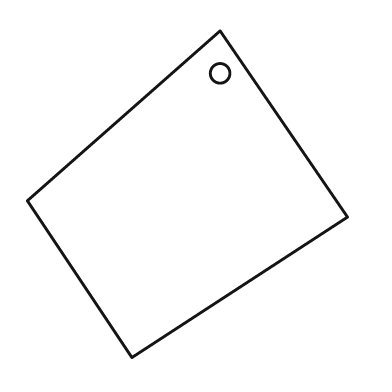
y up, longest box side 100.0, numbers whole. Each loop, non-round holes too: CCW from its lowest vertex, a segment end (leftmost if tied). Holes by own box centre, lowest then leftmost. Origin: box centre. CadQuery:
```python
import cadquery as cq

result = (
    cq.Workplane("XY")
    .moveTo(-17.0, -50.0)
    .lineTo(49.0, -7.0)
    .lineTo(10.0, 50.0)
    .lineTo(-49.0, -2.0)
    .close()
    .moveTo(10.0, 37.0)
    .circle(3.0)
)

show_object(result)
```